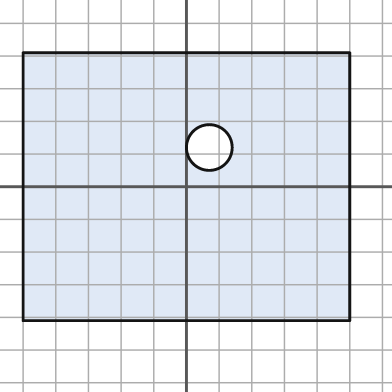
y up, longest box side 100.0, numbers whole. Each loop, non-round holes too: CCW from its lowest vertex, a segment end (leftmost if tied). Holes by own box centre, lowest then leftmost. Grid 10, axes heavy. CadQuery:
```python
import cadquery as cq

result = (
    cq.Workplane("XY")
    .moveTo(-50.0, -41.0)
    .lineTo(50.0, -41.0)
    .lineTo(50.0, 41.0)
    .lineTo(-50.0, 41.0)
    .close()
    .moveTo(7.0, 12.0)
    .circle(7.0)
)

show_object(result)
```